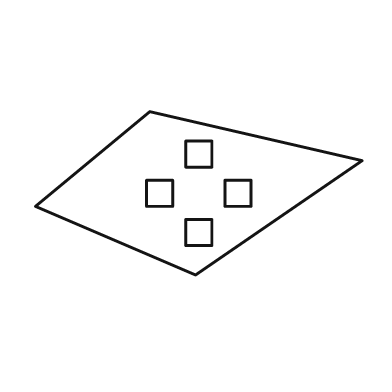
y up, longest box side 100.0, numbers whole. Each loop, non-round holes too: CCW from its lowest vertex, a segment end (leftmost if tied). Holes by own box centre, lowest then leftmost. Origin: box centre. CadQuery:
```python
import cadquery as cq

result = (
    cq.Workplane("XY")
    .moveTo(-1.0, -25.0)
    .lineTo(50.0, 10.0)
    .lineTo(-15.0, 25.0)
    .lineTo(-50.0, -4.0)
    .close()
    .moveTo(-4.0, -16.0)
    .lineTo(4.0, -16.0)
    .lineTo(4.0, -8.0)
    .lineTo(-4.0, -8.0)
    .close()
    .moveTo(-16.0, -4.0)
    .lineTo(-8.0, -4.0)
    .lineTo(-8.0, 4.0)
    .lineTo(-16.0, 4.0)
    .close()
    .moveTo(8.0, -4.0)
    .lineTo(16.0, -4.0)
    .lineTo(16.0, 4.0)
    .lineTo(8.0, 4.0)
    .close()
    .moveTo(-4.0, 8.0)
    .lineTo(4.0, 8.0)
    .lineTo(4.0, 16.0)
    .lineTo(-4.0, 16.0)
    .close()
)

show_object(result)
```